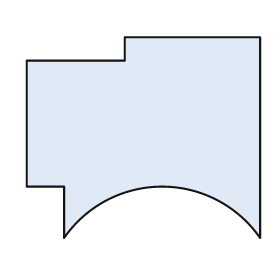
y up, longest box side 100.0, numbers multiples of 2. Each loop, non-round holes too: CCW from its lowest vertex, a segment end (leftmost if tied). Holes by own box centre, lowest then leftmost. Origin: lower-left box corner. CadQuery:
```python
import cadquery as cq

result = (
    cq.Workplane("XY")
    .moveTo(16.0, 0.0)
    .threePointArc((58.0, 22.0), (100.0, 0.0))
    .lineTo(100.0, 86.0)
    .lineTo(42.0, 86.0)
    .lineTo(42.0, 76.0)
    .lineTo(0.0, 76.0)
    .lineTo(0.0, 22.0)
    .lineTo(16.0, 22.0)
    .close()
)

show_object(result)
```